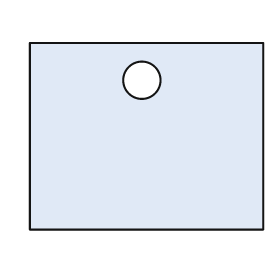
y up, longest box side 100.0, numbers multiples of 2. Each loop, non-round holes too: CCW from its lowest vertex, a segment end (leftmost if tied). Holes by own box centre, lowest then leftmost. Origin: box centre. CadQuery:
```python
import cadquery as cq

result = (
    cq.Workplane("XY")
    .moveTo(-50.0, -40.0)
    .lineTo(50.0, -40.0)
    .lineTo(50.0, 40.0)
    .lineTo(-50.0, 40.0)
    .close()
    .moveTo(-2.0, 24.0)
    .circle(8.0)
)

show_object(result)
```